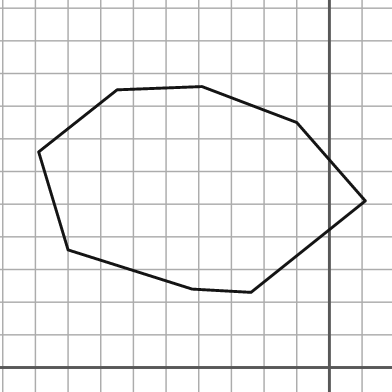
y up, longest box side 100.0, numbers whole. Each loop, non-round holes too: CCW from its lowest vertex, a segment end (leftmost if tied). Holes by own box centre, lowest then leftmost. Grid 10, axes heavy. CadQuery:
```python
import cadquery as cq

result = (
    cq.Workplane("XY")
    .moveTo(-24.0, 23.0)
    .lineTo(11.0, 51.0)
    .lineTo(-10.0, 75.0)
    .lineTo(-39.0, 86.0)
    .lineTo(-65.0, 85.0)
    .lineTo(-89.0, 66.0)
    .lineTo(-80.0, 36.0)
    .lineTo(-42.0, 24.0)
    .close()
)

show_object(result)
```